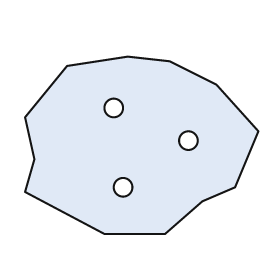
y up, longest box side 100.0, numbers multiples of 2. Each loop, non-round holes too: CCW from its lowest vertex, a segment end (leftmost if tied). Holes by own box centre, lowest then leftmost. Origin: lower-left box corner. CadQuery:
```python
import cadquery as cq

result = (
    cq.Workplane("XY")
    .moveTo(34.0, 0.0)
    .lineTo(60.0, 0.0)
    .lineTo(76.0, 14.0)
    .lineTo(90.0, 20.0)
    .lineTo(100.0, 44.0)
    .lineTo(82.0, 64.0)
    .lineTo(62.0, 74.0)
    .lineTo(44.0, 76.0)
    .lineTo(18.0, 72.0)
    .lineTo(0.0, 50.0)
    .lineTo(4.0, 32.0)
    .lineTo(0.0, 18.0)
    .close()
    .moveTo(42.0, 20.0)
    .circle(4.0)
    .moveTo(70.0, 40.0)
    .circle(4.0)
    .moveTo(38.0, 54.0)
    .circle(4.0)
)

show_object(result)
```